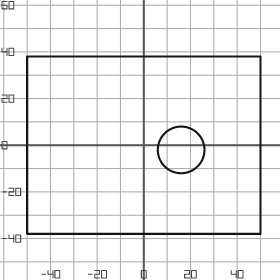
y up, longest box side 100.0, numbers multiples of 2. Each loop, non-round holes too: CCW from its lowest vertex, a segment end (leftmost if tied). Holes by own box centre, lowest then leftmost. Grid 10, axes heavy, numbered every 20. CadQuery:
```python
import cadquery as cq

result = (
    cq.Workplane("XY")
    .moveTo(-50.0, -38.0)
    .lineTo(50.0, -38.0)
    .lineTo(50.0, 38.0)
    .lineTo(-50.0, 38.0)
    .close()
    .moveTo(16.0, -2.0)
    .circle(10.0)
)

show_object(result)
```